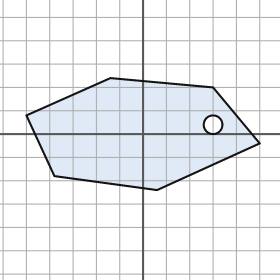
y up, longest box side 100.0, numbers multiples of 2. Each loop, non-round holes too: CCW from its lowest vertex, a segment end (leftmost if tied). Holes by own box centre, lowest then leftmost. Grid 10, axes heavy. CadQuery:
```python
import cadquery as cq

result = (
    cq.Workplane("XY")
    .moveTo(6.0, -24.0)
    .lineTo(50.0, -4.0)
    .lineTo(30.0, 20.0)
    .lineTo(-14.0, 24.0)
    .lineTo(-50.0, 8.0)
    .lineTo(-38.0, -18.0)
    .close()
    .moveTo(30.0, 4.0)
    .circle(4.0)
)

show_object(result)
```